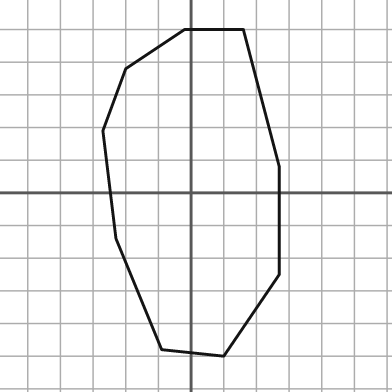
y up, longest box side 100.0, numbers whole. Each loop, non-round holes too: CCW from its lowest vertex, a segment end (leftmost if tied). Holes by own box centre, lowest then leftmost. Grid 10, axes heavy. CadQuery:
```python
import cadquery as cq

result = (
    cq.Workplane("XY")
    .moveTo(10.0, -50.0)
    .lineTo(27.0, -25.0)
    .lineTo(27.0, 8.0)
    .lineTo(16.0, 50.0)
    .lineTo(-2.0, 50.0)
    .lineTo(-20.0, 38.0)
    .lineTo(-27.0, 19.0)
    .lineTo(-23.0, -14.0)
    .lineTo(-9.0, -48.0)
    .close()
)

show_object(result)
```